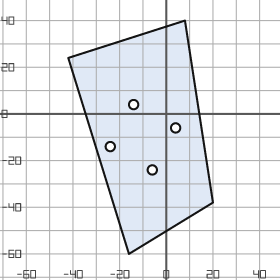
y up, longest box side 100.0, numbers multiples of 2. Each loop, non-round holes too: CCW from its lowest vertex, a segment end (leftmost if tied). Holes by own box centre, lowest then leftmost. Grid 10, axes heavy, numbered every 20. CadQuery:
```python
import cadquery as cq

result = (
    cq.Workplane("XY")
    .moveTo(-16.0, -60.0)
    .lineTo(20.0, -38.0)
    .lineTo(8.0, 40.0)
    .lineTo(-42.0, 24.0)
    .close()
    .moveTo(-6.0, -24.0)
    .circle(2.0)
    .moveTo(-24.0, -14.0)
    .circle(2.0)
    .moveTo(4.0, -6.0)
    .circle(2.0)
    .moveTo(-14.0, 4.0)
    .circle(2.0)
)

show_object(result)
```